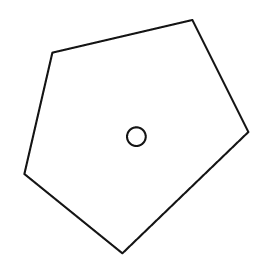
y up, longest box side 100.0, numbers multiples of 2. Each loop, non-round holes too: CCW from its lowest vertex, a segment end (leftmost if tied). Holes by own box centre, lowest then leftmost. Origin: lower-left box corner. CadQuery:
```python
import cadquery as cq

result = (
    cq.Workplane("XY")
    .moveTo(42.0, 0.0)
    .lineTo(96.0, 52.0)
    .lineTo(72.0, 100.0)
    .lineTo(12.0, 86.0)
    .lineTo(0.0, 34.0)
    .close()
    .moveTo(48.0, 50.0)
    .circle(4.0)
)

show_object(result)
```